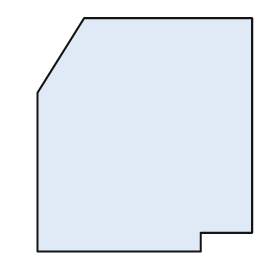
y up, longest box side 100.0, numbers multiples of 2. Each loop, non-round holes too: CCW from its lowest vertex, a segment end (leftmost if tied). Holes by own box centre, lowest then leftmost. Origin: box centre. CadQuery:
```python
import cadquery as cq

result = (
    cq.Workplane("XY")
    .moveTo(-46.0, -50.0)
    .lineTo(24.0, -50.0)
    .lineTo(24.0, -42.0)
    .lineTo(46.0, -42.0)
    .lineTo(46.0, 50.0)
    .lineTo(-26.0, 50.0)
    .lineTo(-46.0, 18.0)
    .close()
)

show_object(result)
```